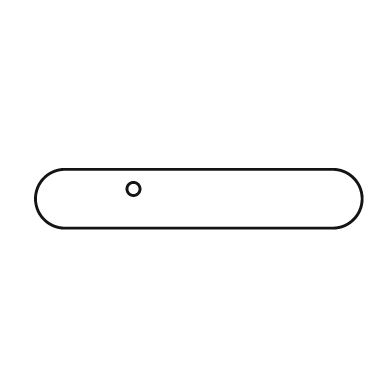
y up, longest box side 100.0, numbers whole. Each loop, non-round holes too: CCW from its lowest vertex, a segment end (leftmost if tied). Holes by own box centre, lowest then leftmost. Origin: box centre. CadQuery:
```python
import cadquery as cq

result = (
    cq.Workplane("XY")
    .moveTo(-41.0, -9.0)
    .lineTo(41.0, -9.0)
    .threePointArc((50.0, 0.0), (41.0, 9.0))
    .lineTo(-41.0, 9.0)
    .threePointArc((-50.0, 0.0), (-41.0, -9.0))
    .close()
    .moveTo(-20.0, 3.0)
    .circle(2.0)
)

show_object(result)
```